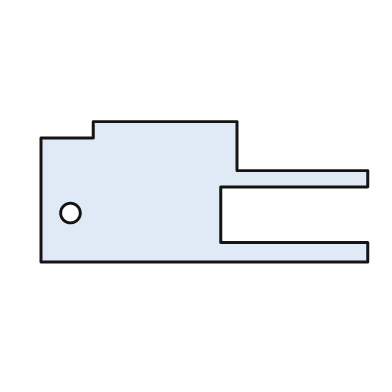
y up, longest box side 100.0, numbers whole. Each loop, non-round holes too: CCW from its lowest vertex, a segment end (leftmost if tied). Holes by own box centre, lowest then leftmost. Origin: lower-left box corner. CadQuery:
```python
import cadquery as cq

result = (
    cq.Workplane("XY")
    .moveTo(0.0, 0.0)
    .lineTo(100.0, 0.0)
    .lineTo(100.0, 6.0)
    .lineTo(55.0, 6.0)
    .lineTo(55.0, 23.0)
    .lineTo(100.0, 23.0)
    .lineTo(100.0, 28.0)
    .lineTo(60.0, 28.0)
    .lineTo(60.0, 43.0)
    .lineTo(16.0, 43.0)
    .lineTo(16.0, 38.0)
    .lineTo(0.0, 38.0)
    .close()
    .moveTo(9.0, 15.0)
    .circle(3.0)
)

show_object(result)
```